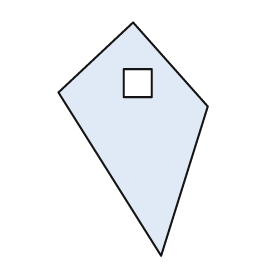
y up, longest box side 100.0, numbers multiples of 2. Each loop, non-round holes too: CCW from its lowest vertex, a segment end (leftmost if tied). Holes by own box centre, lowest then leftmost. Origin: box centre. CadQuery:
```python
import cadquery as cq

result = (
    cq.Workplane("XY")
    .moveTo(12.0, -50.0)
    .lineTo(32.0, 14.0)
    .lineTo(0.0, 50.0)
    .lineTo(-32.0, 20.0)
    .close()
    .moveTo(-4.0, 18.0)
    .lineTo(8.0, 18.0)
    .lineTo(8.0, 30.0)
    .lineTo(-4.0, 30.0)
    .close()
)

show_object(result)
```